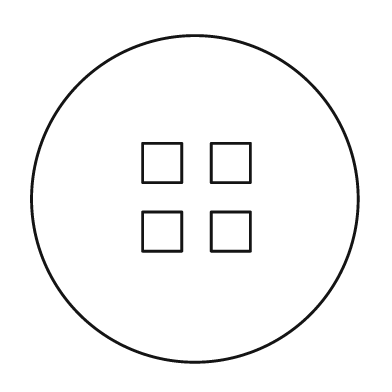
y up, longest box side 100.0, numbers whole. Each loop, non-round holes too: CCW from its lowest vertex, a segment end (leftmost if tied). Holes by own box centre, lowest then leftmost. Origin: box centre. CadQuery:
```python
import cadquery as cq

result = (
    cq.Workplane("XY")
    .moveTo(0.0, 0.0)
    .circle(50.0)
    .moveTo(-16.0, -16.0)
    .lineTo(-4.0, -16.0)
    .lineTo(-4.0, -4.0)
    .lineTo(-16.0, -4.0)
    .close()
    .moveTo(5.0, -16.0)
    .lineTo(17.0, -16.0)
    .lineTo(17.0, -4.0)
    .lineTo(5.0, -4.0)
    .close()
    .moveTo(-16.0, 5.0)
    .lineTo(-4.0, 5.0)
    .lineTo(-4.0, 17.0)
    .lineTo(-16.0, 17.0)
    .close()
    .moveTo(5.0, 5.0)
    .lineTo(17.0, 5.0)
    .lineTo(17.0, 17.0)
    .lineTo(5.0, 17.0)
    .close()
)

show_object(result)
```